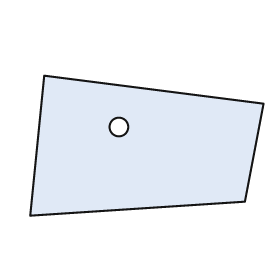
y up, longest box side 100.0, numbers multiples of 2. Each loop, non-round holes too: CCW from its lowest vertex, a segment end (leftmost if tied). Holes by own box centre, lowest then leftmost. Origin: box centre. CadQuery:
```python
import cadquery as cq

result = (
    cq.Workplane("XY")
    .moveTo(-50.0, -30.0)
    .lineTo(42.0, -24.0)
    .lineTo(50.0, 18.0)
    .lineTo(-44.0, 30.0)
    .close()
    .moveTo(-12.0, 8.0)
    .circle(4.0)
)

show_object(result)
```